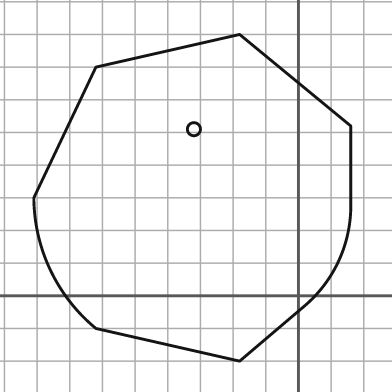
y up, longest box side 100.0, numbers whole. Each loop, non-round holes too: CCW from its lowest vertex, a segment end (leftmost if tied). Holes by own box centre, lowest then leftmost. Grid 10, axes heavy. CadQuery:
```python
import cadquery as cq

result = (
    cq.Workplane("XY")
    .moveTo(-18.0, -20.0)
    .lineTo(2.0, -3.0)
    .threePointArc((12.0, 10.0), (16.0, 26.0))
    .lineTo(16.0, 52.0)
    .lineTo(-18.0, 80.0)
    .lineTo(-62.0, 70.0)
    .lineTo(-81.0, 30.0)
    .threePointArc((-76.0, 8.0), (-62.0, -10.0))
    .close()
    .moveTo(-32.0, 51.0)
    .circle(2.0)
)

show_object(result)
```